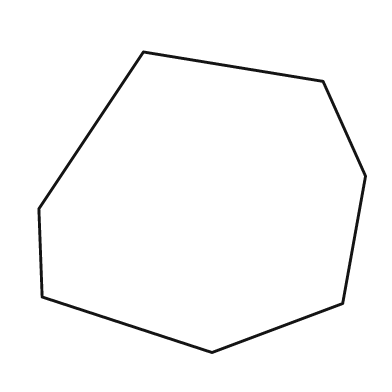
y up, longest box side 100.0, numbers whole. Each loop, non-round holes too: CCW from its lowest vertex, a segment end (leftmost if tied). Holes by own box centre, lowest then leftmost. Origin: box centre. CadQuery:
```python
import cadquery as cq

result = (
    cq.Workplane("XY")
    .moveTo(3.0, -46.0)
    .lineTo(43.0, -31.0)
    .lineTo(50.0, 8.0)
    .lineTo(37.0, 37.0)
    .lineTo(-18.0, 46.0)
    .lineTo(-50.0, -2.0)
    .lineTo(-49.0, -29.0)
    .close()
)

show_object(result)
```